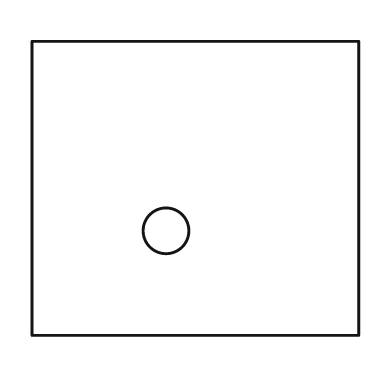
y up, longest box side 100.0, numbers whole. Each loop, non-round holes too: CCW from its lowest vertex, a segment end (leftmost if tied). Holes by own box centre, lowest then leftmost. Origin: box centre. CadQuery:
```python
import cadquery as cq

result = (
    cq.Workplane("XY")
    .moveTo(-50.0, -45.0)
    .lineTo(50.0, -45.0)
    .lineTo(50.0, 45.0)
    .lineTo(-50.0, 45.0)
    .close()
    .moveTo(-9.0, -13.0)
    .circle(7.0)
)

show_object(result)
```